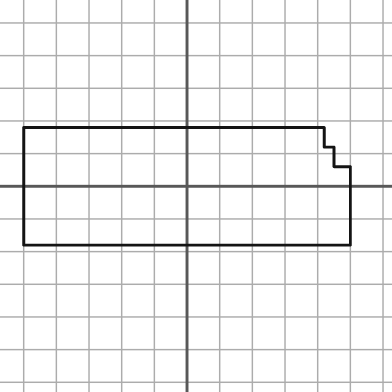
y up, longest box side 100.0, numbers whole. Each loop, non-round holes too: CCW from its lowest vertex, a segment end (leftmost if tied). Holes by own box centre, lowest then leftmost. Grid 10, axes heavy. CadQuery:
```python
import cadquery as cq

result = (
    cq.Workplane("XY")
    .moveTo(-50.0, -18.0)
    .lineTo(50.0, -18.0)
    .lineTo(50.0, 6.0)
    .lineTo(45.0, 6.0)
    .lineTo(45.0, 12.0)
    .lineTo(42.0, 12.0)
    .lineTo(42.0, 18.0)
    .lineTo(-50.0, 18.0)
    .close()
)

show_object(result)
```